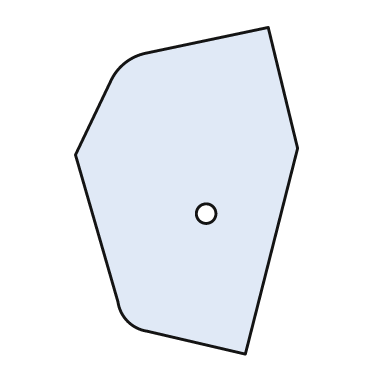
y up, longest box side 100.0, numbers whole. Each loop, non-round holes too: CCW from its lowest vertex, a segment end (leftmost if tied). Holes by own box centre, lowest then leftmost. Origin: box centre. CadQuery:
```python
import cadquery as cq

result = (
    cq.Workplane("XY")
    .moveTo(18.0, -50.0)
    .lineTo(34.0, 13.0)
    .lineTo(25.0, 50.0)
    .lineTo(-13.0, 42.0)
    .threePointArc((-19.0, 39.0), (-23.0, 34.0))
    .lineTo(-34.0, 11.0)
    .lineTo(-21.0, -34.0)
    .threePointArc((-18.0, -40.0), (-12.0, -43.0))
    .close()
    .moveTo(6.0, -7.0)
    .circle(3.0)
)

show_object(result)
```